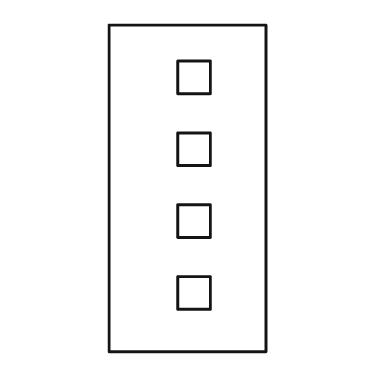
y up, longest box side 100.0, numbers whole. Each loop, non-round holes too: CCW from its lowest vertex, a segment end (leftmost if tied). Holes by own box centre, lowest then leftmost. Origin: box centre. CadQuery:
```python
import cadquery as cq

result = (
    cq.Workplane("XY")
    .moveTo(-24.0, -50.0)
    .lineTo(24.0, -50.0)
    .lineTo(24.0, 50.0)
    .lineTo(-24.0, 50.0)
    .close()
    .moveTo(-3.0, -37.0)
    .lineTo(7.0, -37.0)
    .lineTo(7.0, -27.0)
    .lineTo(-3.0, -27.0)
    .close()
    .moveTo(-3.0, -15.0)
    .lineTo(7.0, -15.0)
    .lineTo(7.0, -5.0)
    .lineTo(-3.0, -5.0)
    .close()
    .moveTo(-3.0, 7.0)
    .lineTo(7.0, 7.0)
    .lineTo(7.0, 17.0)
    .lineTo(-3.0, 17.0)
    .close()
    .moveTo(-3.0, 29.0)
    .lineTo(7.0, 29.0)
    .lineTo(7.0, 39.0)
    .lineTo(-3.0, 39.0)
    .close()
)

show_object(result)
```